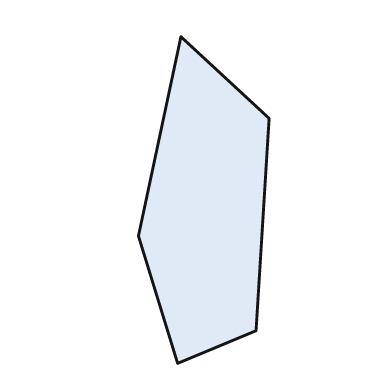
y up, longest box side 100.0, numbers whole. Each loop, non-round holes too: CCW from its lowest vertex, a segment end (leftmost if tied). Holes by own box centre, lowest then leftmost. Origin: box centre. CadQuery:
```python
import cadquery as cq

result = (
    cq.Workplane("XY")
    .moveTo(-8.0, -50.0)
    .lineTo(16.0, -40.0)
    .lineTo(20.0, 25.0)
    .lineTo(-7.0, 50.0)
    .lineTo(-20.0, -11.0)
    .close()
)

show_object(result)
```